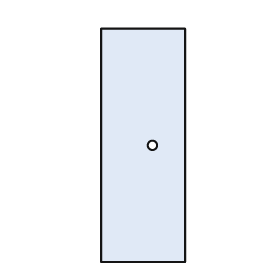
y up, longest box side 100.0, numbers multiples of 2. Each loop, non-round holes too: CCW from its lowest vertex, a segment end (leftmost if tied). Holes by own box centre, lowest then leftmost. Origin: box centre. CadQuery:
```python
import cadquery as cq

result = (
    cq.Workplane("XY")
    .moveTo(-18.0, -50.0)
    .lineTo(18.0, -50.0)
    .lineTo(18.0, 50.0)
    .lineTo(-18.0, 50.0)
    .close()
    .moveTo(4.0, 0.0)
    .circle(2.0)
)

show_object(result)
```